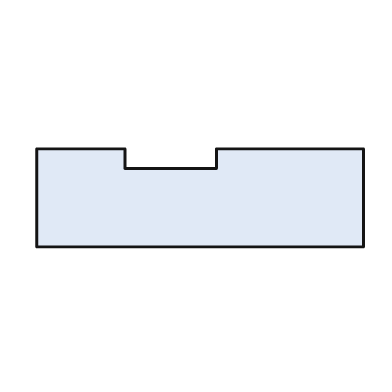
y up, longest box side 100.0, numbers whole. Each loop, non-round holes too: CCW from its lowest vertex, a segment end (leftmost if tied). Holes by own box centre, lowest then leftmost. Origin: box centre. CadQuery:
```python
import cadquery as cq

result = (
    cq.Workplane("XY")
    .moveTo(-50.0, -15.0)
    .lineTo(50.0, -15.0)
    .lineTo(50.0, 15.0)
    .lineTo(5.0, 15.0)
    .lineTo(5.0, 9.0)
    .lineTo(-23.0, 9.0)
    .lineTo(-23.0, 15.0)
    .lineTo(-50.0, 15.0)
    .close()
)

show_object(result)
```